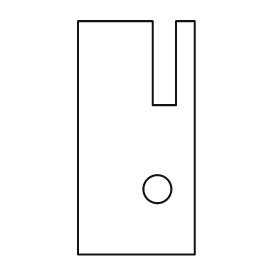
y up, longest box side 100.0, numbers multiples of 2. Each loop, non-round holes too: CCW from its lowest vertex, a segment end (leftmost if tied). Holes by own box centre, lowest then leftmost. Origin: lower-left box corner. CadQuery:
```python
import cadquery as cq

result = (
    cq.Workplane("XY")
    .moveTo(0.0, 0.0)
    .lineTo(50.0, 0.0)
    .lineTo(50.0, 100.0)
    .lineTo(42.0, 100.0)
    .lineTo(42.0, 64.0)
    .lineTo(32.0, 64.0)
    .lineTo(32.0, 100.0)
    .lineTo(0.0, 100.0)
    .close()
    .moveTo(34.0, 28.0)
    .circle(6.0)
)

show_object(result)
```